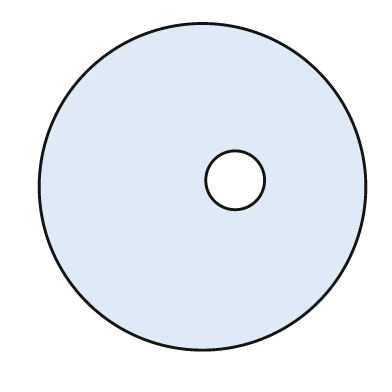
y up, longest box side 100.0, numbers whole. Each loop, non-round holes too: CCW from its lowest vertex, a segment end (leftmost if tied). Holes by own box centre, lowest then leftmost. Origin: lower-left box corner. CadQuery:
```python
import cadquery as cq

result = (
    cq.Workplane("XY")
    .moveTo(50.0, 50.0)
    .circle(50.0)
    .moveTo(60.0, 52.0)
    .circle(9.0)
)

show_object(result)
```